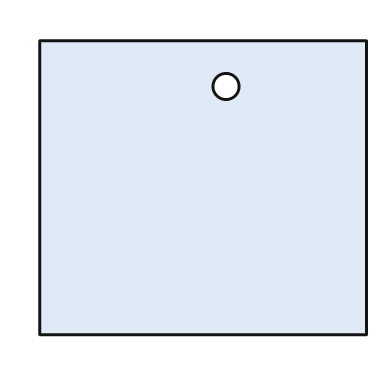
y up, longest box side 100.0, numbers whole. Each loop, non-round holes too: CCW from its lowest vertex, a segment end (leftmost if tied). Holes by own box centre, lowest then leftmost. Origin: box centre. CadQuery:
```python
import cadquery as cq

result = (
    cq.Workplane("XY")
    .moveTo(-50.0, -45.0)
    .lineTo(50.0, -45.0)
    .lineTo(50.0, 45.0)
    .lineTo(-50.0, 45.0)
    .close()
    .moveTo(7.0, 31.0)
    .circle(4.0)
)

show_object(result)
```